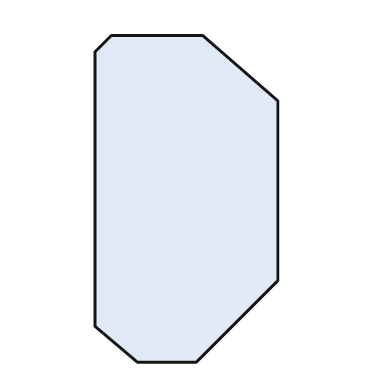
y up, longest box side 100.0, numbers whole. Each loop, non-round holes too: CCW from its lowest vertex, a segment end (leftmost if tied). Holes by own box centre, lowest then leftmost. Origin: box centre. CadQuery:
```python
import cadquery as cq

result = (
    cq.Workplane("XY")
    .moveTo(-15.0, -50.0)
    .lineTo(3.0, -50.0)
    .lineTo(28.0, -25.0)
    .lineTo(28.0, 30.0)
    .lineTo(5.0, 50.0)
    .lineTo(-23.0, 50.0)
    .lineTo(-28.0, 45.0)
    .lineTo(-28.0, -39.0)
    .close()
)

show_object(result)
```